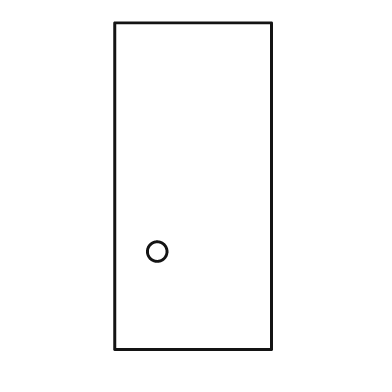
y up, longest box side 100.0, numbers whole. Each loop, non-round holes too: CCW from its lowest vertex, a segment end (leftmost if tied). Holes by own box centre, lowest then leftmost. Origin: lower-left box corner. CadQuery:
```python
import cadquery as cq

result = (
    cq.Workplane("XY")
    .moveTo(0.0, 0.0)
    .lineTo(48.0, 0.0)
    .lineTo(48.0, 100.0)
    .lineTo(0.0, 100.0)
    .close()
    .moveTo(13.0, 30.0)
    .circle(3.0)
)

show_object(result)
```